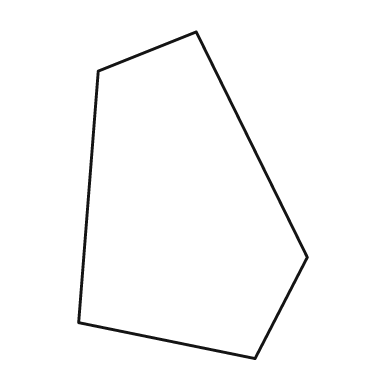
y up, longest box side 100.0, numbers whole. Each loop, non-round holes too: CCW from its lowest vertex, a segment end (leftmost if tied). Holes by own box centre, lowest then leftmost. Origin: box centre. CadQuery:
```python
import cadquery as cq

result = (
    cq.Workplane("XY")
    .moveTo(19.0, -50.0)
    .lineTo(35.0, -19.0)
    .lineTo(1.0, 50.0)
    .lineTo(-29.0, 38.0)
    .lineTo(-35.0, -39.0)
    .close()
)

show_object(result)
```